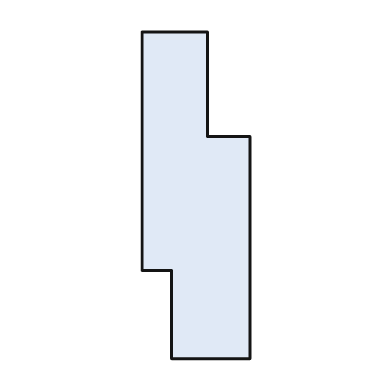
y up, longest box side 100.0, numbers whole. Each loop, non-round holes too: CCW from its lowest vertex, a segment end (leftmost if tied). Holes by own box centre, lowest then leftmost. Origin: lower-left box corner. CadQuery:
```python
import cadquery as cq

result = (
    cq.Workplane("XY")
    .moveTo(9.0, 0.0)
    .lineTo(33.0, 0.0)
    .lineTo(33.0, 68.0)
    .lineTo(20.0, 68.0)
    .lineTo(20.0, 100.0)
    .lineTo(0.0, 100.0)
    .lineTo(0.0, 27.0)
    .lineTo(9.0, 27.0)
    .close()
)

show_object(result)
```